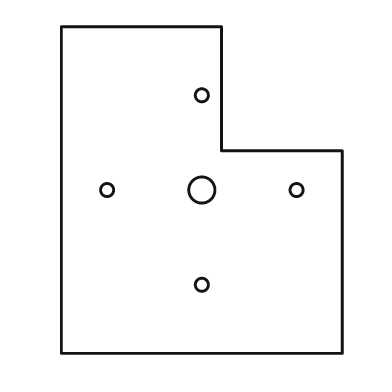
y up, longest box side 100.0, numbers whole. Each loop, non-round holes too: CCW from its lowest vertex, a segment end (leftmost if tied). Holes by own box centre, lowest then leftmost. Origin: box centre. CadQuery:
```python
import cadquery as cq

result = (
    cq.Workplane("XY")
    .moveTo(-43.0, -50.0)
    .lineTo(43.0, -50.0)
    .lineTo(43.0, 12.0)
    .lineTo(6.0, 12.0)
    .lineTo(6.0, 50.0)
    .lineTo(-43.0, 50.0)
    .close()
    .moveTo(0.0, -29.0)
    .circle(2.0)
    .moveTo(-29.0, 0.0)
    .circle(2.0)
    .moveTo(0.0, 0.0)
    .circle(4.0)
    .moveTo(29.0, 0.0)
    .circle(2.0)
    .moveTo(0.0, 29.0)
    .circle(2.0)
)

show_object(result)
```